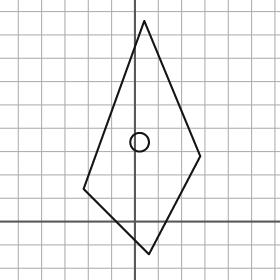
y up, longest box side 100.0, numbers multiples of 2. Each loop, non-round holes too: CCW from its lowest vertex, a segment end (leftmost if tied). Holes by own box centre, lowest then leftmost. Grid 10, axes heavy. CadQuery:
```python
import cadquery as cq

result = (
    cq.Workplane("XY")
    .moveTo(6.0, -14.0)
    .lineTo(28.0, 28.0)
    .lineTo(4.0, 86.0)
    .lineTo(-22.0, 14.0)
    .close()
    .moveTo(2.0, 34.0)
    .circle(4.0)
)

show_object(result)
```